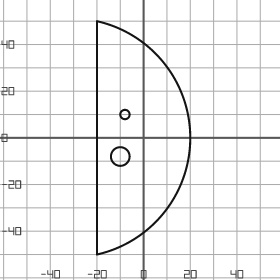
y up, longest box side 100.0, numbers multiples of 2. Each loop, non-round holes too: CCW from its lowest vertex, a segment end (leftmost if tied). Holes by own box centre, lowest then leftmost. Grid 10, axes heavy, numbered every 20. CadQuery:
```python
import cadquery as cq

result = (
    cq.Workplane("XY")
    .moveTo(-20.0, -50.0)
    .threePointArc((20.0, 0.0), (-20.0, 50.0))
    .close()
    .moveTo(-10.0, -8.0)
    .circle(4.0)
    .moveTo(-8.0, 10.0)
    .circle(2.0)
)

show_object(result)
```